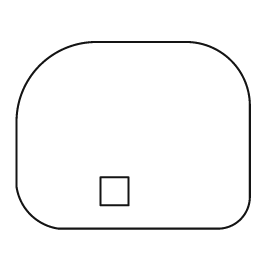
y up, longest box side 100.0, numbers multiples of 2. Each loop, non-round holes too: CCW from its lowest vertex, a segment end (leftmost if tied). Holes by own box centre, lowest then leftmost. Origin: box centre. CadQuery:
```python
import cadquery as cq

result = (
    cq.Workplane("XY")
    .moveTo(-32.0, -40.0)
    .lineTo(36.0, -40.0)
    .threePointArc((46.0, -36.0), (50.0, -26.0))
    .lineTo(50.0, 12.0)
    .threePointArc((42.0, 32.0), (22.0, 40.0))
    .lineTo(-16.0, 40.0)
    .threePointArc((-40.0, 30.0), (-50.0, 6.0))
    .lineTo(-50.0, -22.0)
    .threePointArc((-44.0, -34.0), (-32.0, -40.0))
    .close()
    .moveTo(-14.0, -30.0)
    .lineTo(-2.0, -30.0)
    .lineTo(-2.0, -18.0)
    .lineTo(-14.0, -18.0)
    .close()
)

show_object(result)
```